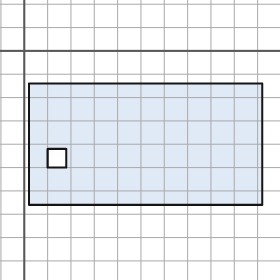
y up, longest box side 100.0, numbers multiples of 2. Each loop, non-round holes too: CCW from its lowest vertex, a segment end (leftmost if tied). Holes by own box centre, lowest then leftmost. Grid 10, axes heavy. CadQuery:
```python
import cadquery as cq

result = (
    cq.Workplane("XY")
    .moveTo(2.0, -66.0)
    .lineTo(102.0, -66.0)
    .lineTo(102.0, -14.0)
    .lineTo(2.0, -14.0)
    .close()
    .moveTo(10.0, -50.0)
    .lineTo(18.0, -50.0)
    .lineTo(18.0, -42.0)
    .lineTo(10.0, -42.0)
    .close()
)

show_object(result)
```